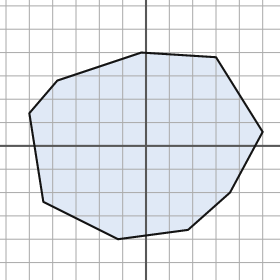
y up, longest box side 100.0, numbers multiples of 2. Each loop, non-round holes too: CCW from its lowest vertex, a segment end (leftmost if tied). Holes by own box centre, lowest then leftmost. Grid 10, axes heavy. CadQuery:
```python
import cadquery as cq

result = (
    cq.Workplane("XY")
    .moveTo(-12.0, -40.0)
    .lineTo(18.0, -36.0)
    .lineTo(36.0, -20.0)
    .lineTo(50.0, 6.0)
    .lineTo(30.0, 38.0)
    .lineTo(-2.0, 40.0)
    .lineTo(-38.0, 28.0)
    .lineTo(-50.0, 14.0)
    .lineTo(-44.0, -24.0)
    .close()
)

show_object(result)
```